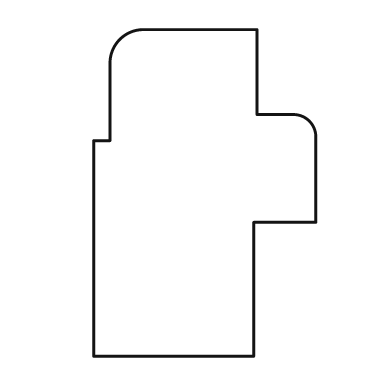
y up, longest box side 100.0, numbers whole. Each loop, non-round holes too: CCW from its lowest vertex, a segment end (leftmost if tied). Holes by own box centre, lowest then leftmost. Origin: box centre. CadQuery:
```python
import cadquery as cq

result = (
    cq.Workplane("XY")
    .moveTo(-34.0, -50.0)
    .lineTo(15.0, -50.0)
    .lineTo(15.0, -9.0)
    .lineTo(34.0, -9.0)
    .lineTo(34.0, 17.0)
    .threePointArc((32.0, 22.0), (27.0, 24.0))
    .lineTo(16.0, 24.0)
    .lineTo(16.0, 50.0)
    .lineTo(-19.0, 50.0)
    .threePointArc((-26.0, 47.0), (-29.0, 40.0))
    .lineTo(-29.0, 16.0)
    .lineTo(-34.0, 16.0)
    .close()
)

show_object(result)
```